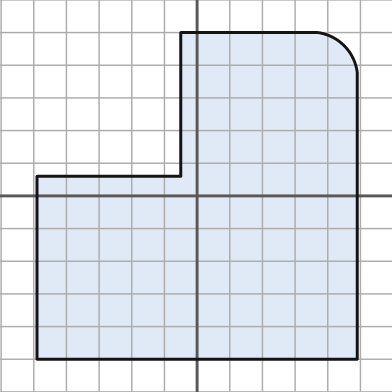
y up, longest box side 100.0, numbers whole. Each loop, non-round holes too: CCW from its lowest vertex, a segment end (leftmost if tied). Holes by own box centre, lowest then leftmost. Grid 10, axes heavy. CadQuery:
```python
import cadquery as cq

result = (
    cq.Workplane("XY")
    .moveTo(-49.0, -50.0)
    .lineTo(49.0, -50.0)
    .lineTo(49.0, 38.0)
    .threePointArc((45.0, 46.0), (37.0, 50.0))
    .lineTo(-5.0, 50.0)
    .lineTo(-5.0, 6.0)
    .lineTo(-49.0, 6.0)
    .close()
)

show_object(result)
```